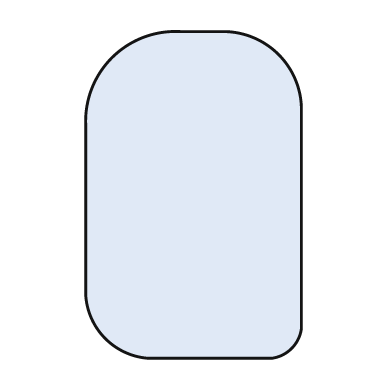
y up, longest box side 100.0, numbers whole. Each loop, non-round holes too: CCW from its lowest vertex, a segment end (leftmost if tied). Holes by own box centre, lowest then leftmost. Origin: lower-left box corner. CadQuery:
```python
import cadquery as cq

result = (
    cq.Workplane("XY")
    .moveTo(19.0, 0.0)
    .lineTo(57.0, 0.0)
    .threePointArc((63.0, 3.0), (66.0, 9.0))
    .lineTo(66.0, 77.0)
    .threePointArc((59.0, 93.0), (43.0, 100.0))
    .lineTo(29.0, 100.0)
    .threePointArc((8.0, 92.0), (0.0, 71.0))
    .lineTo(0.0, 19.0)
    .threePointArc((6.0, 6.0), (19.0, 0.0))
    .close()
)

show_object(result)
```